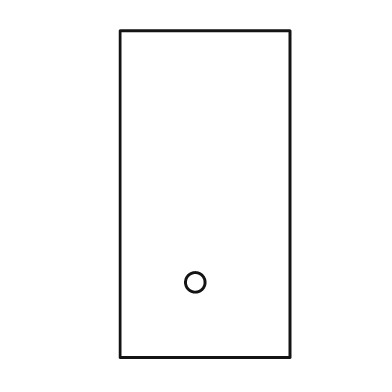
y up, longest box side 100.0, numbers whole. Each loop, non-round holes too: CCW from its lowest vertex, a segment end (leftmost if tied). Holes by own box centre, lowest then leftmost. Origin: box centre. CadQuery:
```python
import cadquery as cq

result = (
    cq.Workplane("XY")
    .moveTo(-26.0, -50.0)
    .lineTo(26.0, -50.0)
    .lineTo(26.0, 50.0)
    .lineTo(-26.0, 50.0)
    .close()
    .moveTo(-3.0, -27.0)
    .circle(3.0)
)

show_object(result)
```